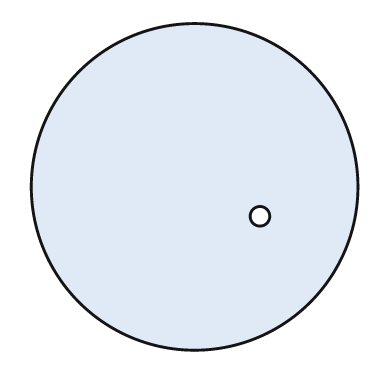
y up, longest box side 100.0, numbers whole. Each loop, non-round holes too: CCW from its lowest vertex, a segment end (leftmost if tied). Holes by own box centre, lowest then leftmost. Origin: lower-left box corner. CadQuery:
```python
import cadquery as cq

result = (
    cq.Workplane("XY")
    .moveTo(50.0, 50.0)
    .circle(50.0)
    .moveTo(70.0, 41.0)
    .circle(3.0)
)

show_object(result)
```